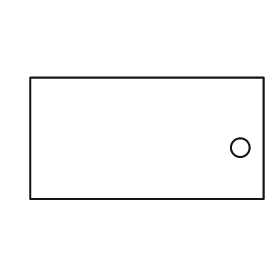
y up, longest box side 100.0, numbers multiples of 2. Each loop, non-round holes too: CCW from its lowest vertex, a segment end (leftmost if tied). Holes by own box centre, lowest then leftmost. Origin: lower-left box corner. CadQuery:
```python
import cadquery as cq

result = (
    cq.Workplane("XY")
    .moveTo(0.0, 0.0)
    .lineTo(100.0, 0.0)
    .lineTo(100.0, 52.0)
    .lineTo(0.0, 52.0)
    .close()
    .moveTo(90.0, 22.0)
    .circle(4.0)
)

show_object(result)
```